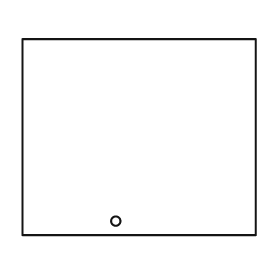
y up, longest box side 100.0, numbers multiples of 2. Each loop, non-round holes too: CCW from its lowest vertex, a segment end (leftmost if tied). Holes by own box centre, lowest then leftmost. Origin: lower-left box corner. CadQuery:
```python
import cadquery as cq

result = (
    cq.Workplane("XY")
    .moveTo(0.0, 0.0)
    .lineTo(100.0, 0.0)
    .lineTo(100.0, 84.0)
    .lineTo(0.0, 84.0)
    .close()
    .moveTo(40.0, 6.0)
    .circle(2.0)
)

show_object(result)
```